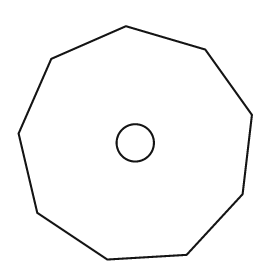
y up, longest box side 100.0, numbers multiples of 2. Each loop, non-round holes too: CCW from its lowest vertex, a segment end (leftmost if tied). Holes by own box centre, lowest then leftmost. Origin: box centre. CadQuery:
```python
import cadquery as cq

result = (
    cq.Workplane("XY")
    .moveTo(-12.0, -50.0)
    .lineTo(22.0, -48.0)
    .lineTo(46.0, -22.0)
    .lineTo(50.0, 12.0)
    .lineTo(30.0, 40.0)
    .lineTo(-4.0, 50.0)
    .lineTo(-36.0, 36.0)
    .lineTo(-50.0, 4.0)
    .lineTo(-42.0, -30.0)
    .close()
    .moveTo(0.0, 0.0)
    .circle(8.0)
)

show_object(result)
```